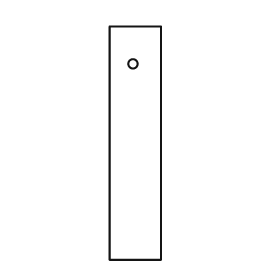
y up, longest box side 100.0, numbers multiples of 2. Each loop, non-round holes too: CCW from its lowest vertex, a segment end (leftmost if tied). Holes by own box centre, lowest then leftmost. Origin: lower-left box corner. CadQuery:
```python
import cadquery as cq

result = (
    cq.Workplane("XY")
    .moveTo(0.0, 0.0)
    .lineTo(22.0, 0.0)
    .lineTo(22.0, 100.0)
    .lineTo(0.0, 100.0)
    .close()
    .moveTo(10.0, 84.0)
    .circle(2.0)
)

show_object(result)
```